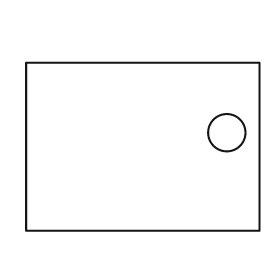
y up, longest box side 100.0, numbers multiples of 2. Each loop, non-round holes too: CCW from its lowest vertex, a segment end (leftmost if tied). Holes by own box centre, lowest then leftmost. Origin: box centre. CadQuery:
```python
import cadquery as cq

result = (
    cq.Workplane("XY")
    .moveTo(-50.0, -36.0)
    .lineTo(50.0, -36.0)
    .lineTo(50.0, 36.0)
    .lineTo(-50.0, 36.0)
    .close()
    .moveTo(36.0, 6.0)
    .circle(8.0)
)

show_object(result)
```